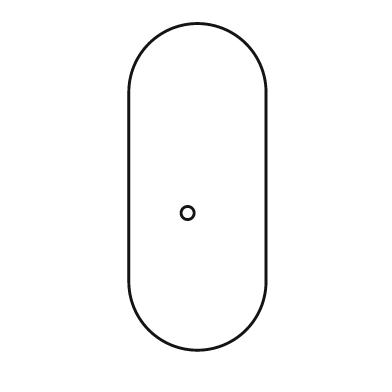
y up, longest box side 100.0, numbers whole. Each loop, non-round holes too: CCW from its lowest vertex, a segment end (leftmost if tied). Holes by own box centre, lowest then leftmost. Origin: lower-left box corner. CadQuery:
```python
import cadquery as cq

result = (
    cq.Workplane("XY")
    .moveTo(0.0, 21.0)
    .threePointArc((21.0, 0.0), (42.0, 21.0))
    .lineTo(42.0, 79.0)
    .threePointArc((21.0, 100.0), (0.0, 79.0))
    .close()
    .moveTo(18.0, 42.0)
    .circle(2.0)
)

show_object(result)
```